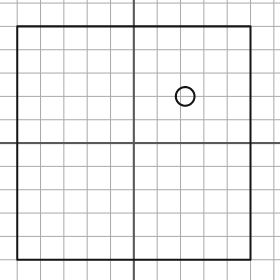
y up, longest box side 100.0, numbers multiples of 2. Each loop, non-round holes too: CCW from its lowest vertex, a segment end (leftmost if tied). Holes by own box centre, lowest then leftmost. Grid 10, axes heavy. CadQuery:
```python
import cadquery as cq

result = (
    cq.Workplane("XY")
    .moveTo(-50.0, -50.0)
    .lineTo(50.0, -50.0)
    .lineTo(50.0, 50.0)
    .lineTo(-50.0, 50.0)
    .close()
    .moveTo(22.0, 20.0)
    .circle(4.0)
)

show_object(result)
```